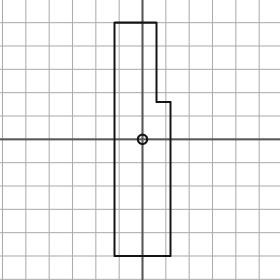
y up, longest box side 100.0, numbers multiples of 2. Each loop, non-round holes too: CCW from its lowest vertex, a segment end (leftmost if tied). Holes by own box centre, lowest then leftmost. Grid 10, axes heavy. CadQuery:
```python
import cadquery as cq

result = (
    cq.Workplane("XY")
    .moveTo(-12.0, -50.0)
    .lineTo(12.0, -50.0)
    .lineTo(12.0, 16.0)
    .lineTo(6.0, 16.0)
    .lineTo(6.0, 50.0)
    .lineTo(-12.0, 50.0)
    .close()
    .moveTo(0.0, 0.0)
    .circle(2.0)
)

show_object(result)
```